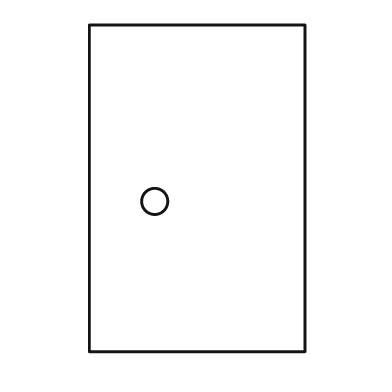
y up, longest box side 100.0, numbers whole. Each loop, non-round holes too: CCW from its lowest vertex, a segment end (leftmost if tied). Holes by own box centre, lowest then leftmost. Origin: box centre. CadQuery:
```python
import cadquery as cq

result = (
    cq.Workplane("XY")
    .moveTo(-33.0, -50.0)
    .lineTo(33.0, -50.0)
    .lineTo(33.0, 50.0)
    .lineTo(-33.0, 50.0)
    .close()
    .moveTo(-13.0, -4.0)
    .circle(4.0)
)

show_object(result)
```